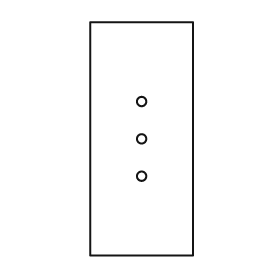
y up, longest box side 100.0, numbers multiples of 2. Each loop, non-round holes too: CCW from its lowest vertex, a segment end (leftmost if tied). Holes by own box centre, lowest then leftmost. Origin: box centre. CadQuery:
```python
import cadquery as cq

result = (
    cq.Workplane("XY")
    .moveTo(-22.0, -50.0)
    .lineTo(22.0, -50.0)
    .lineTo(22.0, 50.0)
    .lineTo(-22.0, 50.0)
    .close()
    .moveTo(0.0, -16.0)
    .circle(2.0)
    .moveTo(0.0, 0.0)
    .circle(2.0)
    .moveTo(0.0, 16.0)
    .circle(2.0)
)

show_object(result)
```